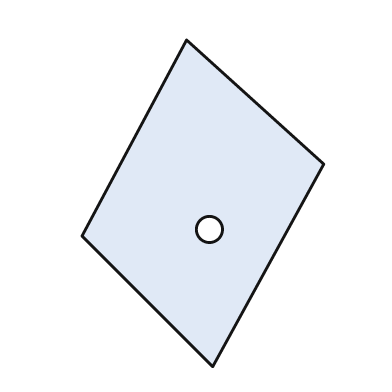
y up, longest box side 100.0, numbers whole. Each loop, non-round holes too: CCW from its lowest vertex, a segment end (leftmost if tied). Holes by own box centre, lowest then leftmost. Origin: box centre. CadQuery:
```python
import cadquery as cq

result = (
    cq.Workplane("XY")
    .moveTo(3.0, -50.0)
    .lineTo(37.0, 12.0)
    .lineTo(-5.0, 50.0)
    .lineTo(-37.0, -10.0)
    .close()
    .moveTo(2.0, -8.0)
    .circle(4.0)
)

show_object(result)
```